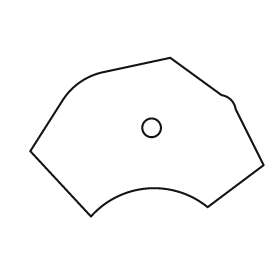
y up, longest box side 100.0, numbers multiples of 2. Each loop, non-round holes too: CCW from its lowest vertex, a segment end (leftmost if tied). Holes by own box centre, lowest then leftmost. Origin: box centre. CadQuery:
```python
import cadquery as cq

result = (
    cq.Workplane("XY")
    .moveTo(-24.0, -34.0)
    .threePointArc((0.0, -22.0), (26.0, -30.0))
    .lineTo(50.0, -12.0)
    .lineTo(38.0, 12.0)
    .threePointArc((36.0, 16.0), (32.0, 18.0))
    .lineTo(10.0, 34.0)
    .lineTo(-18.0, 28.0)
    .threePointArc((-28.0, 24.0), (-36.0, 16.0))
    .lineTo(-50.0, -6.0)
    .close()
    .moveTo(2.0, 4.0)
    .circle(4.0)
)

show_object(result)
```